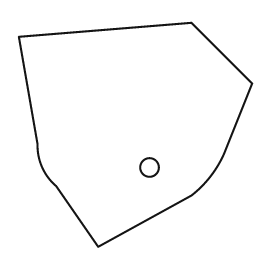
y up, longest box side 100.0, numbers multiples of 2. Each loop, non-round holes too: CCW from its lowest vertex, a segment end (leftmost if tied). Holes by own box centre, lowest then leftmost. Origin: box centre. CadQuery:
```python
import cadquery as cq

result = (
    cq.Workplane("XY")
    .moveTo(-16.0, -48.0)
    .lineTo(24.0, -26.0)
    .threePointArc((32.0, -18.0), (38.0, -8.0))
    .lineTo(50.0, 22.0)
    .lineTo(24.0, 48.0)
    .lineTo(-50.0, 42.0)
    .lineTo(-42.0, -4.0)
    .threePointArc((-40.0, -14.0), (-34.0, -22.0))
    .close()
    .moveTo(6.0, -14.0)
    .circle(4.0)
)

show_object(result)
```